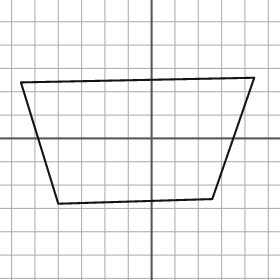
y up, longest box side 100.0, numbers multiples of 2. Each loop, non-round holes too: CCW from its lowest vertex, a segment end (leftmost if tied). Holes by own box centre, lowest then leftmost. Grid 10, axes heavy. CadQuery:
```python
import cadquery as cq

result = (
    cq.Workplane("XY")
    .moveTo(-40.0, -28.0)
    .lineTo(26.0, -26.0)
    .lineTo(44.0, 26.0)
    .lineTo(-56.0, 24.0)
    .close()
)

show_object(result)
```